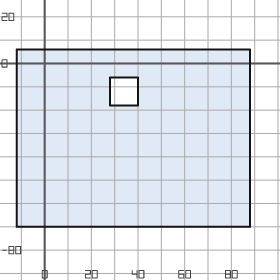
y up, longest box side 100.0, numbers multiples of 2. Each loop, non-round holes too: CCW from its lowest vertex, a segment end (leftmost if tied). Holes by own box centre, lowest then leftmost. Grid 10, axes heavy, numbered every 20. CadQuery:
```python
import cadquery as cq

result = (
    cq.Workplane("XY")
    .moveTo(-12.0, -70.0)
    .lineTo(88.0, -70.0)
    .lineTo(88.0, 6.0)
    .lineTo(-12.0, 6.0)
    .close()
    .moveTo(28.0, -18.0)
    .lineTo(40.0, -18.0)
    .lineTo(40.0, -6.0)
    .lineTo(28.0, -6.0)
    .close()
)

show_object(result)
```